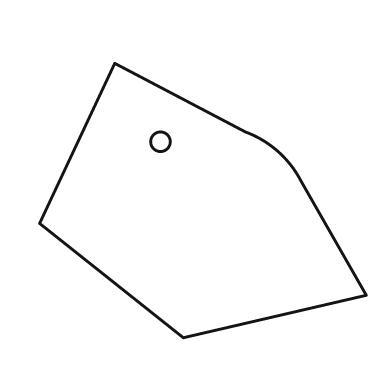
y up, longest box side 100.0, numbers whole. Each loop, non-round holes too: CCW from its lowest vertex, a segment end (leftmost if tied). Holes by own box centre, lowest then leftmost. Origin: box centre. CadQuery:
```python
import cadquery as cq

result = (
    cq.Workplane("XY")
    .moveTo(-6.0, -42.0)
    .lineTo(50.0, -29.0)
    .lineTo(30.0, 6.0)
    .threePointArc((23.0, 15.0), (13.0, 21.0))
    .lineTo(-27.0, 42.0)
    .lineTo(-50.0, -7.0)
    .close()
    .moveTo(-13.0, 18.0)
    .circle(3.0)
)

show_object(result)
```